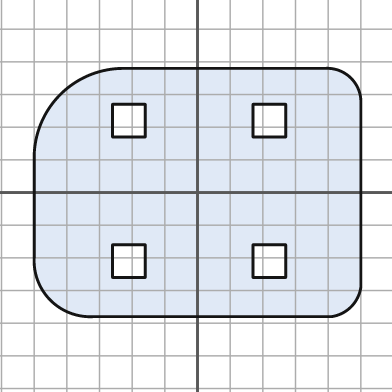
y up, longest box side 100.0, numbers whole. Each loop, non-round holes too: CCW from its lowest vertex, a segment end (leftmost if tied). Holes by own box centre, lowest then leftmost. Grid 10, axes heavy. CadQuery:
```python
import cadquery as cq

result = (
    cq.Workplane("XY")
    .moveTo(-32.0, -38.0)
    .lineTo(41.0, -38.0)
    .threePointArc((47.0, -35.0), (50.0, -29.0))
    .lineTo(50.0, 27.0)
    .threePointArc((47.0, 35.0), (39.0, 38.0))
    .lineTo(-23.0, 38.0)
    .threePointArc((-42.0, 30.0), (-50.0, 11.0))
    .lineTo(-50.0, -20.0)
    .threePointArc((-45.0, -33.0), (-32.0, -38.0))
    .close()
    .moveTo(-26.0, -26.0)
    .lineTo(-16.0, -26.0)
    .lineTo(-16.0, -16.0)
    .lineTo(-26.0, -16.0)
    .close()
    .moveTo(17.0, -26.0)
    .lineTo(27.0, -26.0)
    .lineTo(27.0, -16.0)
    .lineTo(17.0, -16.0)
    .close()
    .moveTo(-26.0, 17.0)
    .lineTo(-16.0, 17.0)
    .lineTo(-16.0, 27.0)
    .lineTo(-26.0, 27.0)
    .close()
    .moveTo(17.0, 17.0)
    .lineTo(27.0, 17.0)
    .lineTo(27.0, 27.0)
    .lineTo(17.0, 27.0)
    .close()
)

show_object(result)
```